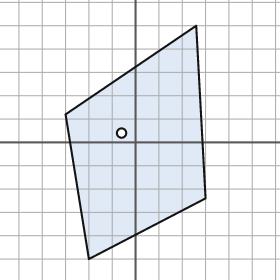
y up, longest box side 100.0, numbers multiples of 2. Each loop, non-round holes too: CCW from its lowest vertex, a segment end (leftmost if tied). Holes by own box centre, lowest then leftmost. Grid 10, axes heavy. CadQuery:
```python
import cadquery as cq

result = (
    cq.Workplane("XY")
    .moveTo(-20.0, -50.0)
    .lineTo(30.0, -24.0)
    .lineTo(26.0, 50.0)
    .lineTo(-30.0, 12.0)
    .close()
    .moveTo(-6.0, 4.0)
    .circle(2.0)
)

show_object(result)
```